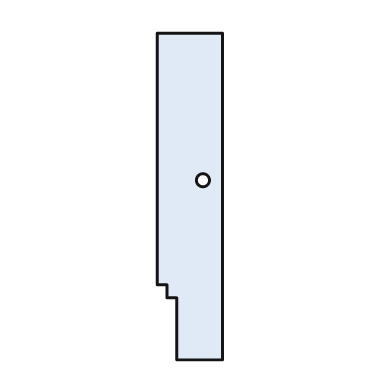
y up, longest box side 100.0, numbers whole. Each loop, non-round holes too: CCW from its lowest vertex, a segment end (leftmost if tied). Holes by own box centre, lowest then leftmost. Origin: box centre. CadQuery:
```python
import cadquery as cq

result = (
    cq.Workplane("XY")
    .moveTo(-4.0, -50.0)
    .lineTo(10.0, -50.0)
    .lineTo(10.0, 50.0)
    .lineTo(-10.0, 50.0)
    .lineTo(-10.0, -27.0)
    .lineTo(-7.0, -27.0)
    .lineTo(-7.0, -31.0)
    .lineTo(-4.0, -31.0)
    .close()
    .moveTo(4.0, 5.0)
    .circle(2.0)
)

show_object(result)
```